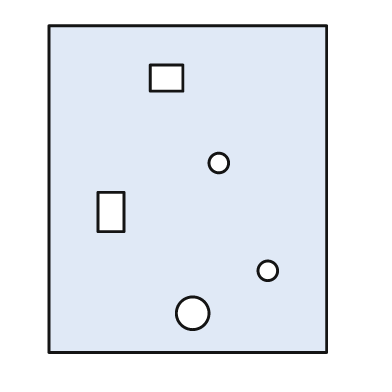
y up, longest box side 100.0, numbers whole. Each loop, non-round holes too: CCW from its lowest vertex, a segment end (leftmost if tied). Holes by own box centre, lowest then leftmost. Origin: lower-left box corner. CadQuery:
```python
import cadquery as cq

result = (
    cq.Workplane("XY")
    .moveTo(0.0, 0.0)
    .lineTo(85.0, 0.0)
    .lineTo(85.0, 100.0)
    .lineTo(0.0, 100.0)
    .close()
    .moveTo(44.0, 12.0)
    .circle(5.0)
    .moveTo(67.0, 25.0)
    .circle(3.0)
    .moveTo(15.0, 37.0)
    .lineTo(23.0, 37.0)
    .lineTo(23.0, 49.0)
    .lineTo(15.0, 49.0)
    .close()
    .moveTo(52.0, 58.0)
    .circle(3.0)
    .moveTo(31.0, 80.0)
    .lineTo(41.0, 80.0)
    .lineTo(41.0, 88.0)
    .lineTo(31.0, 88.0)
    .close()
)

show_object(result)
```